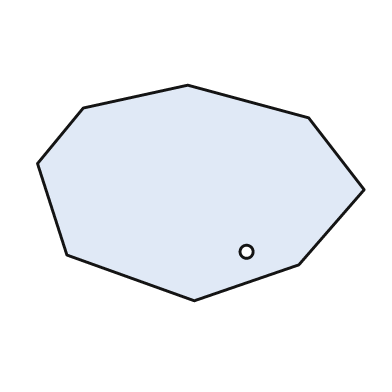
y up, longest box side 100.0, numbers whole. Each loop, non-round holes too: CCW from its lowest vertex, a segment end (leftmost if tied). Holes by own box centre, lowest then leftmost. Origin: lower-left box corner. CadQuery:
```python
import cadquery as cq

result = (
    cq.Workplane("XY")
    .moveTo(48.0, 0.0)
    .lineTo(80.0, 11.0)
    .lineTo(100.0, 34.0)
    .lineTo(83.0, 56.0)
    .lineTo(46.0, 66.0)
    .lineTo(14.0, 59.0)
    .lineTo(0.0, 42.0)
    .lineTo(9.0, 14.0)
    .close()
    .moveTo(64.0, 15.0)
    .circle(2.0)
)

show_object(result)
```